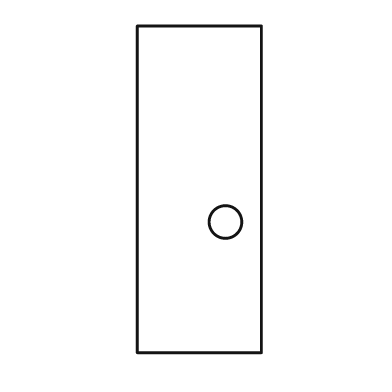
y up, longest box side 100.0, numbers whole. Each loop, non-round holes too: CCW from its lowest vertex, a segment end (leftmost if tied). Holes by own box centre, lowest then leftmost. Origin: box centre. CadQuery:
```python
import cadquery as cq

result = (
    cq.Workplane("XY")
    .moveTo(-19.0, -50.0)
    .lineTo(19.0, -50.0)
    .lineTo(19.0, 50.0)
    .lineTo(-19.0, 50.0)
    .close()
    .moveTo(8.0, -10.0)
    .circle(5.0)
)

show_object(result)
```